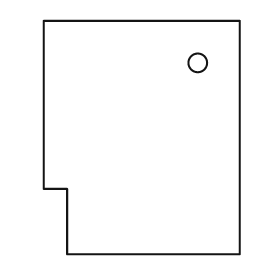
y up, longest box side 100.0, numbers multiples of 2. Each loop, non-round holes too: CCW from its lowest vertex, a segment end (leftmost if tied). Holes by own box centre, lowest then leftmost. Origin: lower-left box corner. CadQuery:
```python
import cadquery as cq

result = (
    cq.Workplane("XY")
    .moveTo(10.0, 0.0)
    .lineTo(84.0, 0.0)
    .lineTo(84.0, 100.0)
    .lineTo(0.0, 100.0)
    .lineTo(0.0, 28.0)
    .lineTo(10.0, 28.0)
    .close()
    .moveTo(66.0, 82.0)
    .circle(4.0)
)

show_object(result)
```